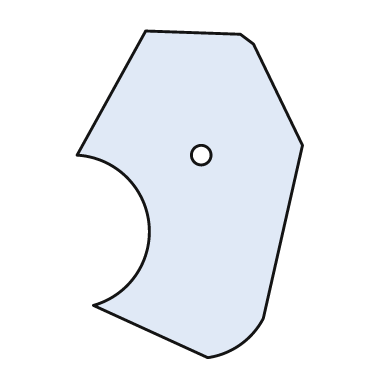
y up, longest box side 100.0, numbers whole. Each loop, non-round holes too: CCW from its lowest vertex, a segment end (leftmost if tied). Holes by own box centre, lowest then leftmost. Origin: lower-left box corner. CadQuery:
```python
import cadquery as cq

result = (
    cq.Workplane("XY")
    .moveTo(40.0, 0.0)
    .threePointArc((50.0, 4.0), (57.0, 12.0))
    .lineTo(69.0, 65.0)
    .lineTo(54.0, 96.0)
    .lineTo(50.0, 99.0)
    .lineTo(21.0, 100.0)
    .lineTo(0.0, 62.0)
    .threePointArc((22.0, 41.0), (5.0, 16.0))
    .close()
    .moveTo(38.0, 62.0)
    .circle(3.0)
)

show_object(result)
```